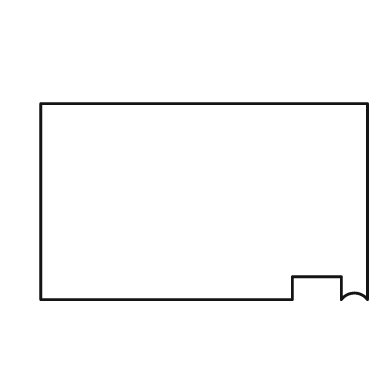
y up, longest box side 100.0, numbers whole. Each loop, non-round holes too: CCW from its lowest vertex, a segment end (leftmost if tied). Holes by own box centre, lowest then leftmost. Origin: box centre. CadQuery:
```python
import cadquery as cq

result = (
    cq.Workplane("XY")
    .moveTo(-50.0, -30.0)
    .lineTo(27.0, -30.0)
    .lineTo(27.0, -23.0)
    .lineTo(42.0, -23.0)
    .lineTo(42.0, -30.0)
    .threePointArc((46.0, -28.0), (50.0, -30.0))
    .lineTo(50.0, 30.0)
    .lineTo(-50.0, 30.0)
    .close()
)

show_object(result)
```